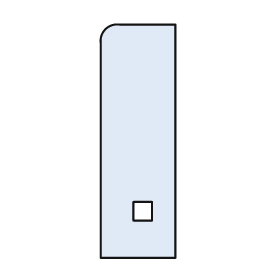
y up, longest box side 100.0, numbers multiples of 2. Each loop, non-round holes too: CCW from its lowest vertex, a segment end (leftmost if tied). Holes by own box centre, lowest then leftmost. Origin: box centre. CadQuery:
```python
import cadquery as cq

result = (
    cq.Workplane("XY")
    .moveTo(-16.0, -50.0)
    .lineTo(16.0, -50.0)
    .lineTo(16.0, 50.0)
    .lineTo(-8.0, 50.0)
    .threePointArc((-14.0, 48.0), (-16.0, 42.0))
    .close()
    .moveTo(-2.0, -34.0)
    .lineTo(6.0, -34.0)
    .lineTo(6.0, -26.0)
    .lineTo(-2.0, -26.0)
    .close()
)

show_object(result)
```